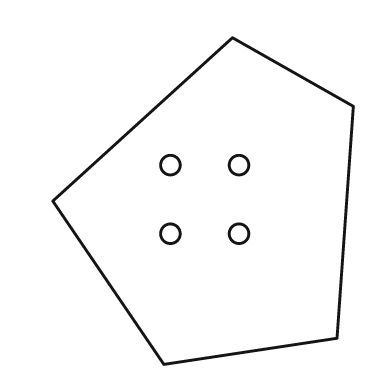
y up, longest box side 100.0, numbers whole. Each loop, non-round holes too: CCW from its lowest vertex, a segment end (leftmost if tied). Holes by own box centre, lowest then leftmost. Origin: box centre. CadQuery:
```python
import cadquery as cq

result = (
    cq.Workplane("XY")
    .moveTo(-12.0, -50.0)
    .lineTo(41.0, -42.0)
    .lineTo(46.0, 29.0)
    .lineTo(9.0, 50.0)
    .lineTo(-46.0, 0.0)
    .close()
    .moveTo(-10.0, -10.0)
    .circle(3.0)
    .moveTo(11.0, -10.0)
    .circle(3.0)
    .moveTo(-10.0, 11.0)
    .circle(3.0)
    .moveTo(11.0, 11.0)
    .circle(3.0)
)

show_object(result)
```